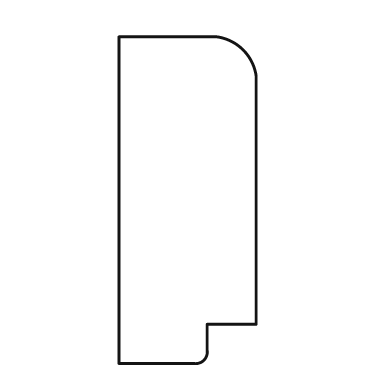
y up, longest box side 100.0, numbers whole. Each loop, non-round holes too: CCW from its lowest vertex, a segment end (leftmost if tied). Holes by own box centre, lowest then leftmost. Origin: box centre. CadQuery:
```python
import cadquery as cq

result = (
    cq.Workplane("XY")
    .moveTo(-21.0, -50.0)
    .lineTo(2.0, -50.0)
    .threePointArc((5.0, -49.0), (6.0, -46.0))
    .lineTo(6.0, -38.0)
    .lineTo(21.0, -38.0)
    .lineTo(21.0, 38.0)
    .threePointArc((17.0, 46.0), (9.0, 50.0))
    .lineTo(-21.0, 50.0)
    .close()
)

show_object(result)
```